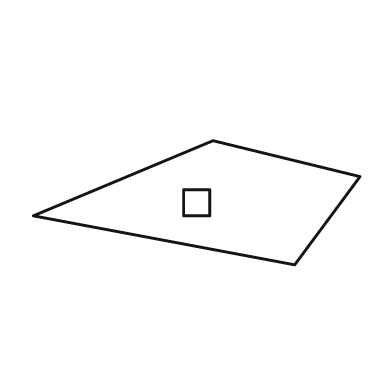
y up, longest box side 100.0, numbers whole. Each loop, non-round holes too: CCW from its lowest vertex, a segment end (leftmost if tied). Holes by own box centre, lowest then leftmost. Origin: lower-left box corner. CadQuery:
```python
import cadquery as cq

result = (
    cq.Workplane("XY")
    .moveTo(80.0, 0.0)
    .lineTo(100.0, 27.0)
    .lineTo(55.0, 38.0)
    .lineTo(0.0, 15.0)
    .close()
    .moveTo(46.0, 15.0)
    .lineTo(54.0, 15.0)
    .lineTo(54.0, 23.0)
    .lineTo(46.0, 23.0)
    .close()
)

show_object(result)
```